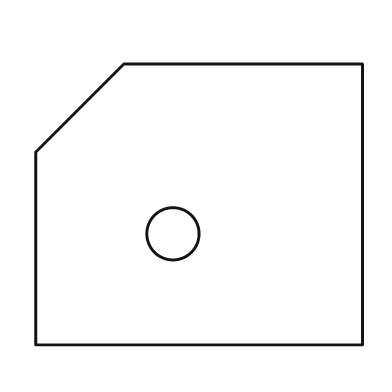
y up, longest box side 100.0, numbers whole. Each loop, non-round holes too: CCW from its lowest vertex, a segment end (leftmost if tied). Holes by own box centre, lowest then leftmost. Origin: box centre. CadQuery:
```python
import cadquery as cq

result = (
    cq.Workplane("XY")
    .moveTo(-50.0, -43.0)
    .lineTo(50.0, -43.0)
    .lineTo(50.0, 43.0)
    .lineTo(-23.0, 43.0)
    .lineTo(-50.0, 16.0)
    .close()
    .moveTo(-8.0, -9.0)
    .circle(8.0)
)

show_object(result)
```